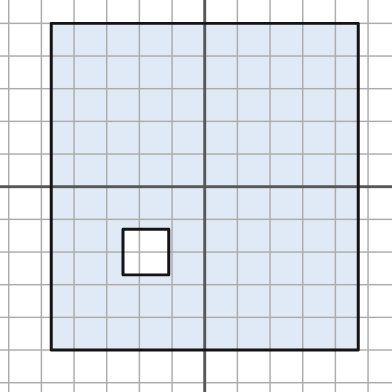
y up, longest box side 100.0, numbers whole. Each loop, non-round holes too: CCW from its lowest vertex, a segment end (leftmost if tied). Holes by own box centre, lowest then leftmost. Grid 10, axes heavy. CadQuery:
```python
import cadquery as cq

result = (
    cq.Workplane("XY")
    .moveTo(-47.0, -50.0)
    .lineTo(47.0, -50.0)
    .lineTo(47.0, 50.0)
    .lineTo(-47.0, 50.0)
    .close()
    .moveTo(-25.0, -27.0)
    .lineTo(-11.0, -27.0)
    .lineTo(-11.0, -13.0)
    .lineTo(-25.0, -13.0)
    .close()
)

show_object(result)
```